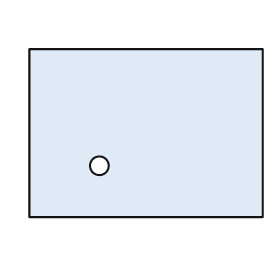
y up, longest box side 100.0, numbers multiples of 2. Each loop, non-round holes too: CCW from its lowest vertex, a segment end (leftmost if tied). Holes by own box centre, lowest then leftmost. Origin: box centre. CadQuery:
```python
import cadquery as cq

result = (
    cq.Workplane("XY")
    .moveTo(-50.0, -36.0)
    .lineTo(50.0, -36.0)
    .lineTo(50.0, 36.0)
    .lineTo(-50.0, 36.0)
    .close()
    .moveTo(-20.0, -14.0)
    .circle(4.0)
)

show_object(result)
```